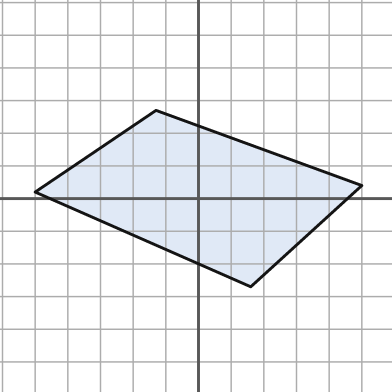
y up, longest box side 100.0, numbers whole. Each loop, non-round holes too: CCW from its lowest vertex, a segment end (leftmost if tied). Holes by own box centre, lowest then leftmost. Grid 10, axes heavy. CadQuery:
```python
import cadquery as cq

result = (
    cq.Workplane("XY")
    .moveTo(16.0, -27.0)
    .lineTo(50.0, 4.0)
    .lineTo(-13.0, 27.0)
    .lineTo(-50.0, 2.0)
    .close()
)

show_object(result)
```